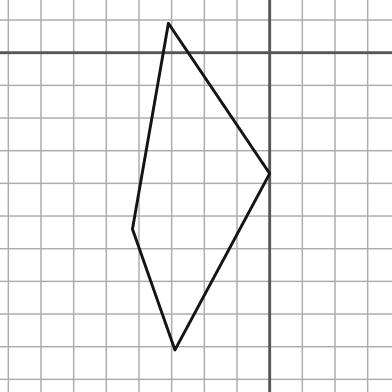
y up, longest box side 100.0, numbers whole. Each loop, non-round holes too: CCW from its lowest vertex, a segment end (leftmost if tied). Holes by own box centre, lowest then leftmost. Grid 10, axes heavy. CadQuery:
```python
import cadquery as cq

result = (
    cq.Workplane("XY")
    .moveTo(-29.0, -91.0)
    .lineTo(0.0, -37.0)
    .lineTo(-31.0, 9.0)
    .lineTo(-42.0, -54.0)
    .close()
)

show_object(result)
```